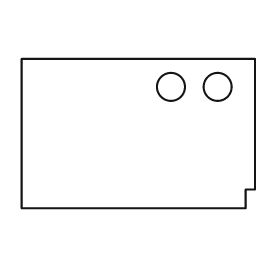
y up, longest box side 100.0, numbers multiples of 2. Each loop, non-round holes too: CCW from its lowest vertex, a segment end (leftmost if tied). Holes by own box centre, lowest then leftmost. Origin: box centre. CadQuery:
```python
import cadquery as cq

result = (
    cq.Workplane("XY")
    .moveTo(-50.0, -32.0)
    .lineTo(46.0, -32.0)
    .lineTo(46.0, -24.0)
    .lineTo(50.0, -24.0)
    .lineTo(50.0, 32.0)
    .lineTo(-50.0, 32.0)
    .close()
    .moveTo(14.0, 20.0)
    .circle(6.0)
    .moveTo(34.0, 20.0)
    .circle(6.0)
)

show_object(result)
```